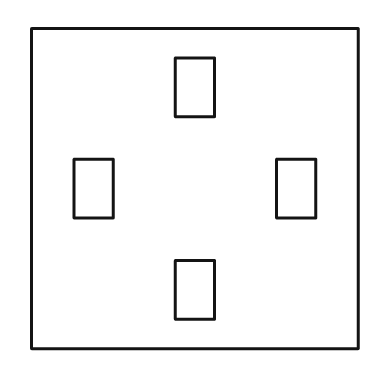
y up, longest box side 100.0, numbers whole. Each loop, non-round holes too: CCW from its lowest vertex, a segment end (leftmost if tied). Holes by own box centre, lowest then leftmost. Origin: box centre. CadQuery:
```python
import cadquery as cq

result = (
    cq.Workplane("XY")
    .moveTo(-50.0, -49.0)
    .lineTo(50.0, -49.0)
    .lineTo(50.0, 49.0)
    .lineTo(-50.0, 49.0)
    .close()
    .moveTo(-6.0, -40.0)
    .lineTo(6.0, -40.0)
    .lineTo(6.0, -22.0)
    .lineTo(-6.0, -22.0)
    .close()
    .moveTo(-37.0, -9.0)
    .lineTo(-25.0, -9.0)
    .lineTo(-25.0, 9.0)
    .lineTo(-37.0, 9.0)
    .close()
    .moveTo(25.0, -9.0)
    .lineTo(37.0, -9.0)
    .lineTo(37.0, 9.0)
    .lineTo(25.0, 9.0)
    .close()
    .moveTo(-6.0, 22.0)
    .lineTo(6.0, 22.0)
    .lineTo(6.0, 40.0)
    .lineTo(-6.0, 40.0)
    .close()
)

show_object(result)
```